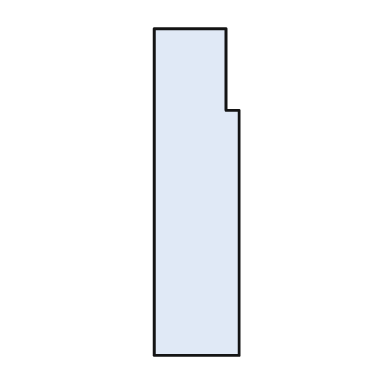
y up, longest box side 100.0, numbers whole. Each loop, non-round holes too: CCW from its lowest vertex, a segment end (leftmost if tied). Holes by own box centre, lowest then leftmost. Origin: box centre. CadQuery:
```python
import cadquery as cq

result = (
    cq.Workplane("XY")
    .moveTo(-13.0, -50.0)
    .lineTo(13.0, -50.0)
    .lineTo(13.0, 25.0)
    .lineTo(9.0, 25.0)
    .lineTo(9.0, 50.0)
    .lineTo(-13.0, 50.0)
    .close()
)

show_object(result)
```